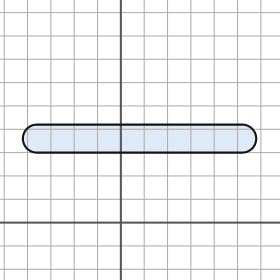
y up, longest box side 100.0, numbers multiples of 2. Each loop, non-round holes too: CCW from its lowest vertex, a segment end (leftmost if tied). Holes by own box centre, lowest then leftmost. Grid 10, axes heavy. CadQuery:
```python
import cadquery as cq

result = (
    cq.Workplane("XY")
    .moveTo(-36.0, 30.0)
    .lineTo(52.0, 30.0)
    .threePointArc((58.0, 36.0), (52.0, 42.0))
    .lineTo(-36.0, 42.0)
    .threePointArc((-42.0, 36.0), (-36.0, 30.0))
    .close()
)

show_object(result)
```